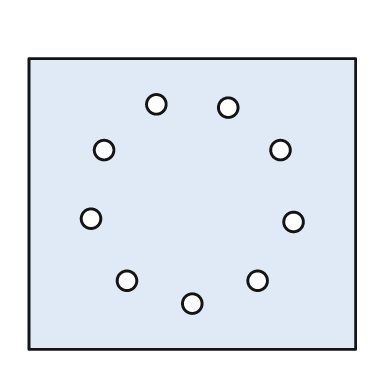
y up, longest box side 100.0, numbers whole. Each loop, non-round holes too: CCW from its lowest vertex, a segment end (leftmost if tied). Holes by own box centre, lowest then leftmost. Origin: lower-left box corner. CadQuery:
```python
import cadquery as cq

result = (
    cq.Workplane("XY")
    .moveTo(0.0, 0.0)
    .lineTo(100.0, 0.0)
    .lineTo(100.0, 89.0)
    .lineTo(0.0, 89.0)
    .close()
    .moveTo(50.0, 14.0)
    .circle(3.0)
    .moveTo(30.0, 21.0)
    .circle(3.0)
    .moveTo(70.0, 21.0)
    .circle(3.0)
    .moveTo(81.0, 39.0)
    .circle(3.0)
    .moveTo(19.0, 40.0)
    .circle(3.0)
    .moveTo(23.0, 61.0)
    .circle(3.0)
    .moveTo(77.0, 61.0)
    .circle(3.0)
    .moveTo(61.0, 74.0)
    .circle(3.0)
    .moveTo(39.0, 75.0)
    .circle(3.0)
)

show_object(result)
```